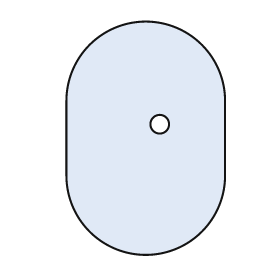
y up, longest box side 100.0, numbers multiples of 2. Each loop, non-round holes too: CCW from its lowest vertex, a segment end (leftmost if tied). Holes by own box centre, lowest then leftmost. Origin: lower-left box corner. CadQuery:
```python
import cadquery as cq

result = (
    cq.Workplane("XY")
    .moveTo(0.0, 34.0)
    .threePointArc((34.0, 0.0), (68.0, 34.0))
    .lineTo(68.0, 66.0)
    .threePointArc((34.0, 100.0), (0.0, 66.0))
    .close()
    .moveTo(40.0, 56.0)
    .circle(4.0)
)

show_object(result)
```